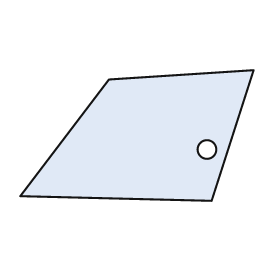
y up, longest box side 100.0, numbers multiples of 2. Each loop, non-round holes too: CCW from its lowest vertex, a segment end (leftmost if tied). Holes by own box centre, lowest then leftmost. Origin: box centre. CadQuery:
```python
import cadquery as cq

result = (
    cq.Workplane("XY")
    .moveTo(32.0, -28.0)
    .lineTo(50.0, 28.0)
    .lineTo(-12.0, 24.0)
    .lineTo(-50.0, -26.0)
    .close()
    .moveTo(30.0, -6.0)
    .circle(4.0)
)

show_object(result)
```